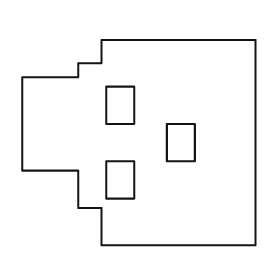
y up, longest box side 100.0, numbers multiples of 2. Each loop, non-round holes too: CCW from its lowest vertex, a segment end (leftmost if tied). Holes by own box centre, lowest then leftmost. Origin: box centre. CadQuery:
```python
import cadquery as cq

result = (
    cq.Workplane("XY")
    .moveTo(-16.0, -44.0)
    .lineTo(50.0, -44.0)
    .lineTo(50.0, 44.0)
    .lineTo(-16.0, 44.0)
    .lineTo(-16.0, 34.0)
    .lineTo(-26.0, 34.0)
    .lineTo(-26.0, 28.0)
    .lineTo(-50.0, 28.0)
    .lineTo(-50.0, -12.0)
    .lineTo(-26.0, -12.0)
    .lineTo(-26.0, -28.0)
    .lineTo(-16.0, -28.0)
    .close()
    .moveTo(-14.0, -24.0)
    .lineTo(-2.0, -24.0)
    .lineTo(-2.0, -8.0)
    .lineTo(-14.0, -8.0)
    .close()
    .moveTo(12.0, -8.0)
    .lineTo(24.0, -8.0)
    .lineTo(24.0, 8.0)
    .lineTo(12.0, 8.0)
    .close()
    .moveTo(-14.0, 8.0)
    .lineTo(-2.0, 8.0)
    .lineTo(-2.0, 24.0)
    .lineTo(-14.0, 24.0)
    .close()
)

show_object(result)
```